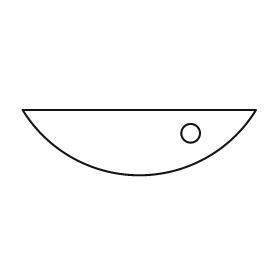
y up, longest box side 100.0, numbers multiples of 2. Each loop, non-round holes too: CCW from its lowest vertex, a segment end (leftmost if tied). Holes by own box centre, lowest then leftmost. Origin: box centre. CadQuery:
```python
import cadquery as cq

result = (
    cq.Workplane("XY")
    .moveTo(-50.0, 14.0)
    .threePointArc((0.0, -14.0), (50.0, 14.0))
    .close()
    .moveTo(22.0, 4.0)
    .circle(4.0)
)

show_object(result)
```